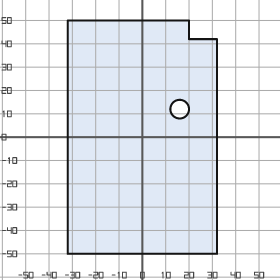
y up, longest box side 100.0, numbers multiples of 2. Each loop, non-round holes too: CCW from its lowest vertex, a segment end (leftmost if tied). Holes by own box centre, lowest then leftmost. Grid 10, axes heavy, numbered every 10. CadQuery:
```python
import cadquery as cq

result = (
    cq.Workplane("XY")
    .moveTo(-32.0, -50.0)
    .lineTo(32.0, -50.0)
    .lineTo(32.0, 42.0)
    .lineTo(20.0, 42.0)
    .lineTo(20.0, 50.0)
    .lineTo(-32.0, 50.0)
    .close()
    .moveTo(16.0, 12.0)
    .circle(4.0)
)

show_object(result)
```